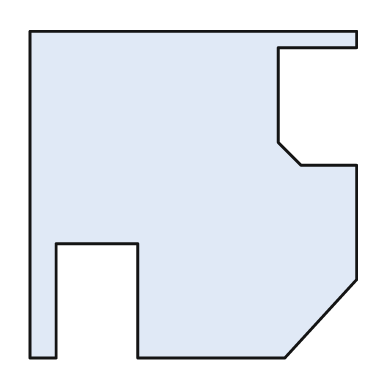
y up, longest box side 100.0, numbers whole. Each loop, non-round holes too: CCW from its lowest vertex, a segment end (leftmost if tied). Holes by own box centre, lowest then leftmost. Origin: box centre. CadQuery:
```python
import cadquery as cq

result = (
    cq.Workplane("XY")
    .moveTo(-50.0, -50.0)
    .lineTo(-42.0, -50.0)
    .lineTo(-42.0, -15.0)
    .lineTo(-17.0, -15.0)
    .lineTo(-17.0, -50.0)
    .lineTo(28.0, -50.0)
    .lineTo(50.0, -26.0)
    .lineTo(50.0, 9.0)
    .lineTo(33.0, 9.0)
    .lineTo(26.0, 16.0)
    .lineTo(26.0, 45.0)
    .lineTo(50.0, 45.0)
    .lineTo(50.0, 50.0)
    .lineTo(-50.0, 50.0)
    .close()
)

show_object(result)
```